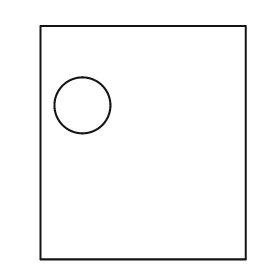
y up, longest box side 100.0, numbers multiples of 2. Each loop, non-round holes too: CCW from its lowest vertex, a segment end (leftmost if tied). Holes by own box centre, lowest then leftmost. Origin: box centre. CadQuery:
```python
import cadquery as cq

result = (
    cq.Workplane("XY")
    .moveTo(-44.0, -50.0)
    .lineTo(44.0, -50.0)
    .lineTo(44.0, 50.0)
    .lineTo(-44.0, 50.0)
    .close()
    .moveTo(-26.0, 16.0)
    .circle(12.0)
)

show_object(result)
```